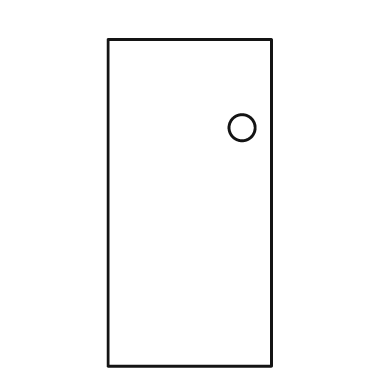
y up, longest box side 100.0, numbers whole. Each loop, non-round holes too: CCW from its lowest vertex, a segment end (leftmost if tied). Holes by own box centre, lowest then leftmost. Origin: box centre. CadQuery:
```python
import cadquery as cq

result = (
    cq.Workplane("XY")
    .moveTo(-25.0, -50.0)
    .lineTo(25.0, -50.0)
    .lineTo(25.0, 50.0)
    .lineTo(-25.0, 50.0)
    .close()
    .moveTo(16.0, 23.0)
    .circle(4.0)
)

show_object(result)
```